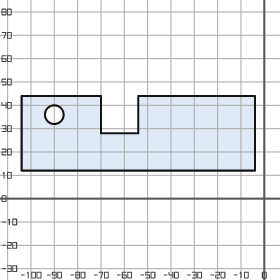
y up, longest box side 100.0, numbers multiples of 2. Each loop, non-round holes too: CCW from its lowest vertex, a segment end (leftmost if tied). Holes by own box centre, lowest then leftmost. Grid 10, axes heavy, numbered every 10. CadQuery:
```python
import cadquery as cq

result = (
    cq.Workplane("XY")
    .moveTo(-104.0, 12.0)
    .lineTo(-4.0, 12.0)
    .lineTo(-4.0, 44.0)
    .lineTo(-54.0, 44.0)
    .lineTo(-54.0, 28.0)
    .lineTo(-70.0, 28.0)
    .lineTo(-70.0, 44.0)
    .lineTo(-104.0, 44.0)
    .close()
    .moveTo(-90.0, 36.0)
    .circle(4.0)
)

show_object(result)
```